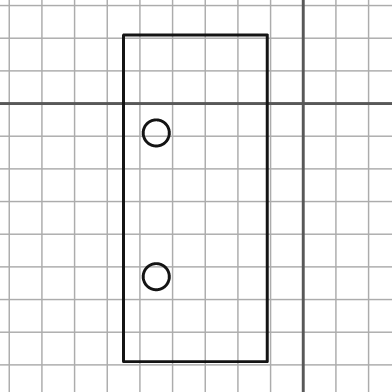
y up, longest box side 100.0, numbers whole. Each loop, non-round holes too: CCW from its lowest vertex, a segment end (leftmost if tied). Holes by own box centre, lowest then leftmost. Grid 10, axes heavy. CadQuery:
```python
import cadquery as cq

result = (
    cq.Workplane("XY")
    .moveTo(-55.0, -79.0)
    .lineTo(-11.0, -79.0)
    .lineTo(-11.0, 21.0)
    .lineTo(-55.0, 21.0)
    .close()
    .moveTo(-45.0, -53.0)
    .circle(4.0)
    .moveTo(-45.0, -9.0)
    .circle(4.0)
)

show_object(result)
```